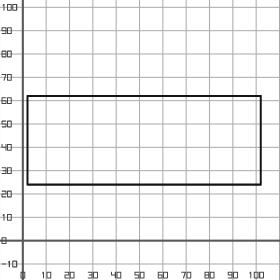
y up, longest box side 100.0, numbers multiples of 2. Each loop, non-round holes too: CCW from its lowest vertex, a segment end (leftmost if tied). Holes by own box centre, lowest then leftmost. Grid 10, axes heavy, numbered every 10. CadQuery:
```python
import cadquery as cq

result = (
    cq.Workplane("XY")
    .moveTo(2.0, 24.0)
    .lineTo(102.0, 24.0)
    .lineTo(102.0, 62.0)
    .lineTo(2.0, 62.0)
    .close()
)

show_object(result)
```